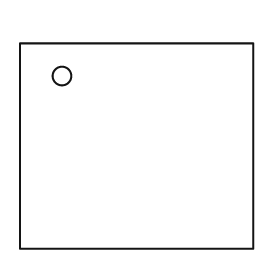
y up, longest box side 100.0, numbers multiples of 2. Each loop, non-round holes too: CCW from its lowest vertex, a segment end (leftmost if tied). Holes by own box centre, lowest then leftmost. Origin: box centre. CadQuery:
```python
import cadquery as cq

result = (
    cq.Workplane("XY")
    .moveTo(-50.0, -44.0)
    .lineTo(50.0, -44.0)
    .lineTo(50.0, 44.0)
    .lineTo(-50.0, 44.0)
    .close()
    .moveTo(-32.0, 30.0)
    .circle(4.0)
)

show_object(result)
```